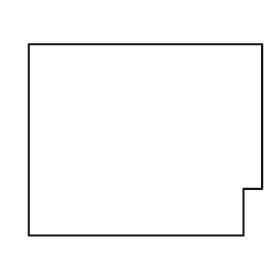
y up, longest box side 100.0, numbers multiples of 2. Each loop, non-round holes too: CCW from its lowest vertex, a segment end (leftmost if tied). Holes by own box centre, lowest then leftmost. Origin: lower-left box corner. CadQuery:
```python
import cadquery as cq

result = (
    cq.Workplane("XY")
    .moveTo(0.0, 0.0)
    .lineTo(92.0, 0.0)
    .lineTo(92.0, 20.0)
    .lineTo(100.0, 20.0)
    .lineTo(100.0, 82.0)
    .lineTo(0.0, 82.0)
    .close()
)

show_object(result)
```